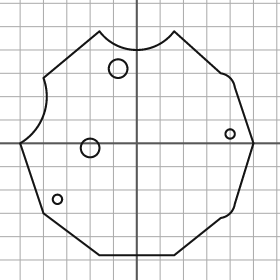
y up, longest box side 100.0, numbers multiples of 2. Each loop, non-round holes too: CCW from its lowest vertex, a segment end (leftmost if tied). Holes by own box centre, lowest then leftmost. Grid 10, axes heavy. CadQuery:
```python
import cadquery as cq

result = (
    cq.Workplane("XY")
    .moveTo(-16.0, -48.0)
    .lineTo(16.0, -48.0)
    .lineTo(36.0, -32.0)
    .threePointArc((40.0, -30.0), (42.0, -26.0))
    .lineTo(50.0, 0.0)
    .lineTo(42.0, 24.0)
    .threePointArc((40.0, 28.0), (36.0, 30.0))
    .lineTo(16.0, 48.0)
    .threePointArc((0.0, 40.0), (-16.0, 48.0))
    .lineTo(-40.0, 28.0)
    .threePointArc((-40.0, 12.0), (-50.0, 0.0))
    .lineTo(-40.0, -30.0)
    .close()
    .moveTo(-34.0, -24.0)
    .circle(2.0)
    .moveTo(-20.0, -2.0)
    .circle(4.0)
    .moveTo(40.0, 4.0)
    .circle(2.0)
    .moveTo(-8.0, 32.0)
    .circle(4.0)
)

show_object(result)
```